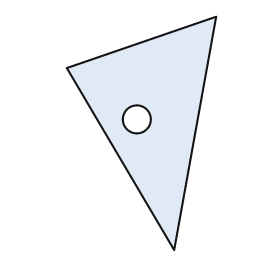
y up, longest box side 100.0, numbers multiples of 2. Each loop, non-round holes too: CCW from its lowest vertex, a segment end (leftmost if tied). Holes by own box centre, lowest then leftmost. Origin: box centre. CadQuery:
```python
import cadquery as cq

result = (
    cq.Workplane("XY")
    .moveTo(14.0, -50.0)
    .lineTo(32.0, 50.0)
    .lineTo(-32.0, 28.0)
    .close()
    .moveTo(-2.0, 6.0)
    .circle(6.0)
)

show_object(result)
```